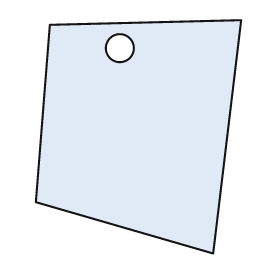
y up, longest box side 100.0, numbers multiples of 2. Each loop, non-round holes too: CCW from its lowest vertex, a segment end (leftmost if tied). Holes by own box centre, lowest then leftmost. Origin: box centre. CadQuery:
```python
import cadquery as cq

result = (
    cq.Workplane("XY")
    .moveTo(32.0, -50.0)
    .lineTo(44.0, 50.0)
    .lineTo(-38.0, 48.0)
    .lineTo(-44.0, -28.0)
    .close()
    .moveTo(-8.0, 38.0)
    .circle(6.0)
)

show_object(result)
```